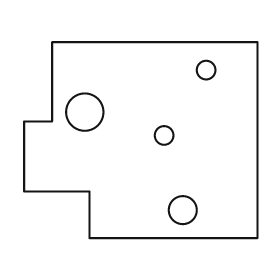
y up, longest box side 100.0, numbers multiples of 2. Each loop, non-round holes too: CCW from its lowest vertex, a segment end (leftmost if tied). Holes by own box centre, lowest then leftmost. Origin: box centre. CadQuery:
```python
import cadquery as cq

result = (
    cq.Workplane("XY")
    .moveTo(-22.0, -42.0)
    .lineTo(50.0, -42.0)
    .lineTo(50.0, 42.0)
    .lineTo(-38.0, 42.0)
    .lineTo(-38.0, 8.0)
    .lineTo(-50.0, 8.0)
    .lineTo(-50.0, -22.0)
    .lineTo(-22.0, -22.0)
    .close()
    .moveTo(18.0, -30.0)
    .circle(6.0)
    .moveTo(10.0, 2.0)
    .circle(4.0)
    .moveTo(-24.0, 12.0)
    .circle(8.0)
    .moveTo(28.0, 30.0)
    .circle(4.0)
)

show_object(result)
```